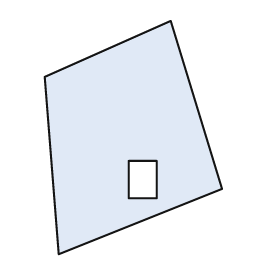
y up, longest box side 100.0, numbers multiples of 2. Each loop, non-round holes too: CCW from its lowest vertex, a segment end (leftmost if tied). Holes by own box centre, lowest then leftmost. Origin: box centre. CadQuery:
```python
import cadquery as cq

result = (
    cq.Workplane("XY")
    .moveTo(-32.0, -50.0)
    .lineTo(38.0, -22.0)
    .lineTo(16.0, 50.0)
    .lineTo(-38.0, 26.0)
    .close()
    .moveTo(-2.0, -26.0)
    .lineTo(10.0, -26.0)
    .lineTo(10.0, -10.0)
    .lineTo(-2.0, -10.0)
    .close()
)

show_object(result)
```